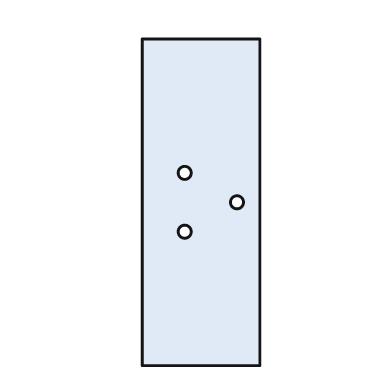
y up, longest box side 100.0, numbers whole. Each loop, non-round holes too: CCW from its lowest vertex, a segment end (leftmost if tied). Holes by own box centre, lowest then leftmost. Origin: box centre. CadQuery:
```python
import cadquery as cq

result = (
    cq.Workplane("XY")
    .moveTo(-18.0, -50.0)
    .lineTo(18.0, -50.0)
    .lineTo(18.0, 50.0)
    .lineTo(-18.0, 50.0)
    .close()
    .moveTo(-5.0, -9.0)
    .circle(2.0)
    .moveTo(11.0, 0.0)
    .circle(2.0)
    .moveTo(-5.0, 9.0)
    .circle(2.0)
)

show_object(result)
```